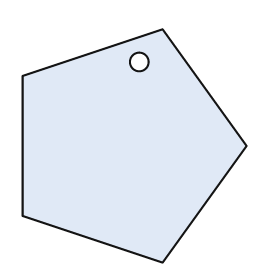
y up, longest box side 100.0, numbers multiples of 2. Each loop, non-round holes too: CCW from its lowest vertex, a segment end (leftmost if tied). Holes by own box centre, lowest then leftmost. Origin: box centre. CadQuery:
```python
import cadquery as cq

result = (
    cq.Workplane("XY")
    .moveTo(12.0, -50.0)
    .lineTo(48.0, 0.0)
    .lineTo(12.0, 50.0)
    .lineTo(-48.0, 30.0)
    .lineTo(-48.0, -30.0)
    .close()
    .moveTo(2.0, 36.0)
    .circle(4.0)
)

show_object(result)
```